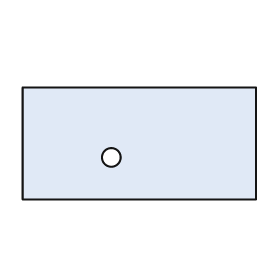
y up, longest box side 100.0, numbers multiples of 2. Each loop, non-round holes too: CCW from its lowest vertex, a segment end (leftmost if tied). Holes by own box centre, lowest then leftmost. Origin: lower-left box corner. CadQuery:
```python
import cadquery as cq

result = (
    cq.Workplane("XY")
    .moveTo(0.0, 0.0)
    .lineTo(100.0, 0.0)
    .lineTo(100.0, 48.0)
    .lineTo(0.0, 48.0)
    .close()
    .moveTo(38.0, 18.0)
    .circle(4.0)
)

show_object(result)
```